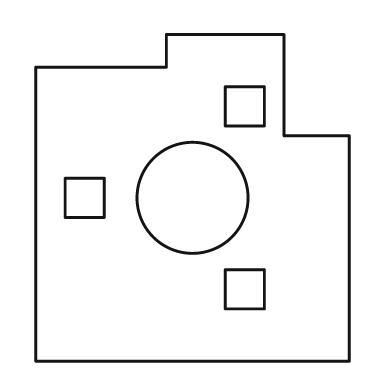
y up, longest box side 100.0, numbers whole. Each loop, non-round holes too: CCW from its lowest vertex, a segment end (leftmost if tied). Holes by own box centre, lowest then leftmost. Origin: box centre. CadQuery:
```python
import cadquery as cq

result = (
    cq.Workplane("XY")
    .moveTo(-48.0, -50.0)
    .lineTo(48.0, -50.0)
    .lineTo(48.0, 19.0)
    .lineTo(28.0, 19.0)
    .lineTo(28.0, 50.0)
    .lineTo(-8.0, 50.0)
    .lineTo(-8.0, 40.0)
    .lineTo(-48.0, 40.0)
    .close()
    .moveTo(10.0, -34.0)
    .lineTo(22.0, -34.0)
    .lineTo(22.0, -22.0)
    .lineTo(10.0, -22.0)
    .close()
    .moveTo(-39.0, -6.0)
    .lineTo(-27.0, -6.0)
    .lineTo(-27.0, 6.0)
    .lineTo(-39.0, 6.0)
    .close()
    .moveTo(0.0, 0.0)
    .circle(17.0)
    .moveTo(10.0, 22.0)
    .lineTo(22.0, 22.0)
    .lineTo(22.0, 34.0)
    .lineTo(10.0, 34.0)
    .close()
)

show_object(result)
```